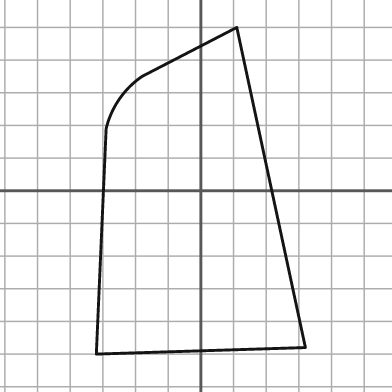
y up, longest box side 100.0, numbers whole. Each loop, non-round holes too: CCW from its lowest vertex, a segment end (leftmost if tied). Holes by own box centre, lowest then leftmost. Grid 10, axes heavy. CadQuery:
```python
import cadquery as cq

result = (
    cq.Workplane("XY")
    .moveTo(-32.0, -50.0)
    .lineTo(32.0, -48.0)
    .lineTo(11.0, 50.0)
    .lineTo(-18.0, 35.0)
    .threePointArc((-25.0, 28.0), (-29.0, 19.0))
    .close()
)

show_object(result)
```